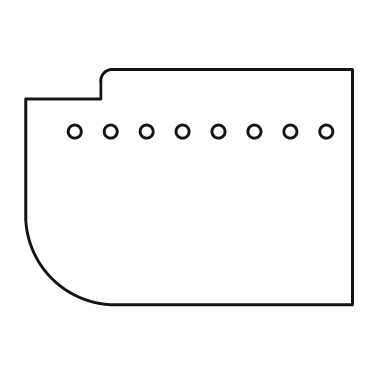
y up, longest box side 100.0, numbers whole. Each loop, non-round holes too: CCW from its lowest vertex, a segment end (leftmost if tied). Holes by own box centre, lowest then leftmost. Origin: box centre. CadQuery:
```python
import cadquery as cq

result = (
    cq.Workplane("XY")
    .moveTo(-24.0, -36.0)
    .lineTo(50.0, -36.0)
    .lineTo(50.0, 36.0)
    .lineTo(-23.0, 36.0)
    .threePointArc((-26.0, 35.0), (-27.0, 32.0))
    .lineTo(-27.0, 27.0)
    .lineTo(-50.0, 27.0)
    .lineTo(-50.0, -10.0)
    .threePointArc((-42.0, -28.0), (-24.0, -36.0))
    .close()
    .moveTo(-35.0, 17.0)
    .circle(2.0)
    .moveTo(-24.0, 17.0)
    .circle(2.0)
    .moveTo(-13.0, 17.0)
    .circle(2.0)
    .moveTo(-2.0, 17.0)
    .circle(2.0)
    .moveTo(9.0, 17.0)
    .circle(2.0)
    .moveTo(20.0, 17.0)
    .circle(2.0)
    .moveTo(31.0, 17.0)
    .circle(2.0)
    .moveTo(42.0, 17.0)
    .circle(2.0)
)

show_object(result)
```